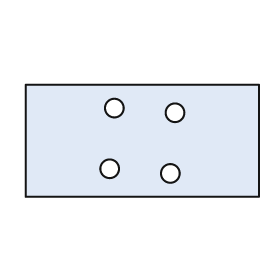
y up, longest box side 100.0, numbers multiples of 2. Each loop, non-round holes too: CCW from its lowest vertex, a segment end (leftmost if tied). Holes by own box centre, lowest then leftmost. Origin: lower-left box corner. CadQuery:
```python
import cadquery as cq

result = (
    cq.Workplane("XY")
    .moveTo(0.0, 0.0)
    .lineTo(100.0, 0.0)
    .lineTo(100.0, 48.0)
    .lineTo(0.0, 48.0)
    .close()
    .moveTo(62.0, 10.0)
    .circle(4.0)
    .moveTo(36.0, 12.0)
    .circle(4.0)
    .moveTo(64.0, 36.0)
    .circle(4.0)
    .moveTo(38.0, 38.0)
    .circle(4.0)
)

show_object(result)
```